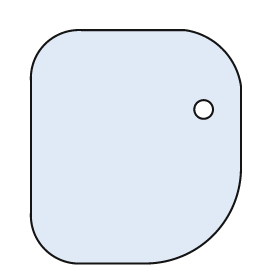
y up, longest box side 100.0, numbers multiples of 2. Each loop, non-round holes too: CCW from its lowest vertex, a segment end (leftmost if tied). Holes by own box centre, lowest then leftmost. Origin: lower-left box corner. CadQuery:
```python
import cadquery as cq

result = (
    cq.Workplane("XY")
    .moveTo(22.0, 0.0)
    .lineTo(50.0, 0.0)
    .threePointArc((78.0, 12.0), (90.0, 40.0))
    .lineTo(90.0, 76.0)
    .threePointArc((82.0, 92.0), (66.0, 100.0))
    .lineTo(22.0, 100.0)
    .threePointArc((6.0, 94.0), (0.0, 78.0))
    .lineTo(0.0, 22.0)
    .threePointArc((6.0, 6.0), (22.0, 0.0))
    .close()
    .moveTo(74.0, 66.0)
    .circle(4.0)
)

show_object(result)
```